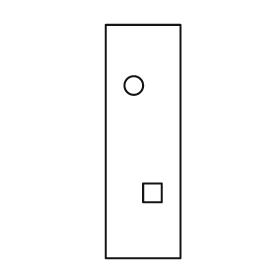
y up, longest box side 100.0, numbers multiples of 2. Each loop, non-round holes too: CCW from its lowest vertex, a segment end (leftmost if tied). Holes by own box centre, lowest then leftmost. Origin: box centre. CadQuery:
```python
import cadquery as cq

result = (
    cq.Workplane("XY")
    .moveTo(-16.0, -50.0)
    .lineTo(16.0, -50.0)
    .lineTo(16.0, 50.0)
    .lineTo(-16.0, 50.0)
    .close()
    .moveTo(0.0, -26.0)
    .lineTo(8.0, -26.0)
    .lineTo(8.0, -18.0)
    .lineTo(0.0, -18.0)
    .close()
    .moveTo(-4.0, 24.0)
    .circle(4.0)
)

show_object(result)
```